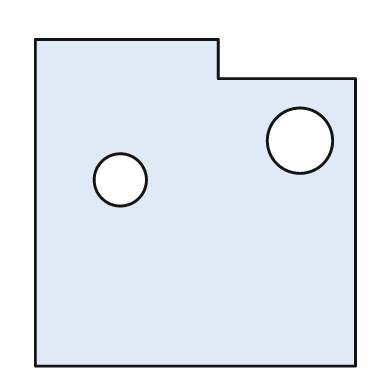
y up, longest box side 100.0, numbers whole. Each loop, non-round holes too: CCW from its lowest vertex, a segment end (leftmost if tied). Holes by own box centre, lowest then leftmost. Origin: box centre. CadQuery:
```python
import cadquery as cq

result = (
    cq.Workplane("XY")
    .moveTo(-49.0, -50.0)
    .lineTo(49.0, -50.0)
    .lineTo(49.0, 38.0)
    .lineTo(7.0, 38.0)
    .lineTo(7.0, 50.0)
    .lineTo(-49.0, 50.0)
    .close()
    .moveTo(-23.0, 7.0)
    .circle(8.0)
    .moveTo(32.0, 19.0)
    .circle(10.0)
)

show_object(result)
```